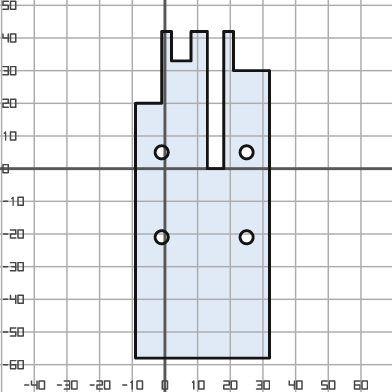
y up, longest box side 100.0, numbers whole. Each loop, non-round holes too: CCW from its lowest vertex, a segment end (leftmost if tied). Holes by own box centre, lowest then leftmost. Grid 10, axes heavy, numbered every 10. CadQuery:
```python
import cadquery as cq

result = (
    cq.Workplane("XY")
    .moveTo(-9.0, -58.0)
    .lineTo(32.0, -58.0)
    .lineTo(32.0, 30.0)
    .lineTo(21.0, 30.0)
    .lineTo(21.0, 42.0)
    .lineTo(18.0, 42.0)
    .lineTo(18.0, 0.0)
    .lineTo(13.0, 0.0)
    .lineTo(13.0, 42.0)
    .lineTo(8.0, 42.0)
    .lineTo(8.0, 33.0)
    .lineTo(2.0, 33.0)
    .lineTo(2.0, 42.0)
    .lineTo(-1.0, 42.0)
    .lineTo(-1.0, 20.0)
    .lineTo(-9.0, 20.0)
    .close()
    .moveTo(-1.0, -21.0)
    .circle(2.0)
    .moveTo(25.0, -21.0)
    .circle(2.0)
    .moveTo(-1.0, 5.0)
    .circle(2.0)
    .moveTo(25.0, 5.0)
    .circle(2.0)
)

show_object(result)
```